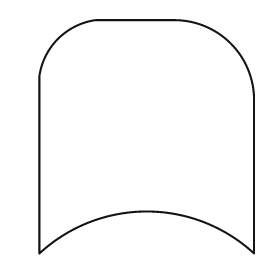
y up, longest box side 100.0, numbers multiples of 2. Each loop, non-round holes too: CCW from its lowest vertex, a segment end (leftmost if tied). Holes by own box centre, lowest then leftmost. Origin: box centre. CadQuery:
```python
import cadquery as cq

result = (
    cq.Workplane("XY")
    .moveTo(-46.0, -50.0)
    .threePointArc((0.0, -32.0), (46.0, -50.0))
    .lineTo(46.0, 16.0)
    .threePointArc((36.0, 40.0), (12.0, 50.0))
    .lineTo(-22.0, 50.0)
    .threePointArc((-38.0, 42.0), (-46.0, 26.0))
    .close()
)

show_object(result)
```